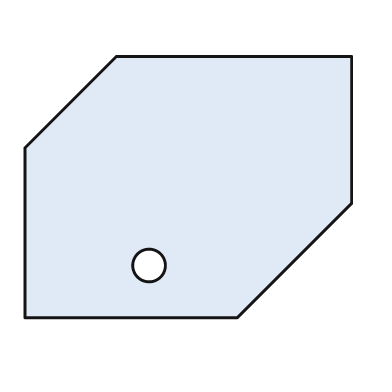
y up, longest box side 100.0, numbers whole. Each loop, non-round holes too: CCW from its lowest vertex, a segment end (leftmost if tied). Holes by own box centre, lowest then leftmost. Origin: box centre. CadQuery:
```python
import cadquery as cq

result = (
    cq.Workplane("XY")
    .moveTo(-50.0, -40.0)
    .lineTo(15.0, -40.0)
    .lineTo(50.0, -5.0)
    .lineTo(50.0, 40.0)
    .lineTo(-22.0, 40.0)
    .lineTo(-50.0, 12.0)
    .close()
    .moveTo(-12.0, -24.0)
    .circle(5.0)
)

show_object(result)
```